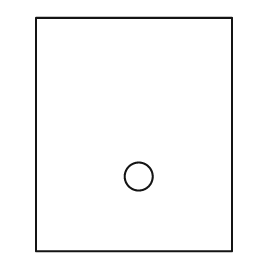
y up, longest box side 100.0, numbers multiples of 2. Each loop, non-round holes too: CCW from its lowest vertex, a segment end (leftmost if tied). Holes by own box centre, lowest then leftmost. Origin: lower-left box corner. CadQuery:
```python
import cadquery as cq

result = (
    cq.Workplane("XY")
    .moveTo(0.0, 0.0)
    .lineTo(84.0, 0.0)
    .lineTo(84.0, 100.0)
    .lineTo(0.0, 100.0)
    .close()
    .moveTo(44.0, 32.0)
    .circle(6.0)
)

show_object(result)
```